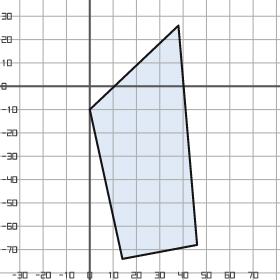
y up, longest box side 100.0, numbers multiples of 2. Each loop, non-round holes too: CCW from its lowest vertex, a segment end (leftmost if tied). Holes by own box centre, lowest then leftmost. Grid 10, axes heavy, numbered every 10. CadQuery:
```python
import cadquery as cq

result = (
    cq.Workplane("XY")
    .moveTo(14.0, -74.0)
    .lineTo(46.0, -68.0)
    .lineTo(38.0, 26.0)
    .lineTo(0.0, -10.0)
    .close()
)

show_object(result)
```